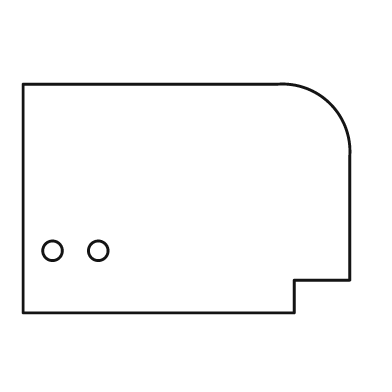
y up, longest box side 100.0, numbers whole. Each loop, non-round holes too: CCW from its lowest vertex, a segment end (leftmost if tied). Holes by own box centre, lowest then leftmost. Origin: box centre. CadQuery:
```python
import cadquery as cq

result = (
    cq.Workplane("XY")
    .moveTo(-50.0, -35.0)
    .lineTo(33.0, -35.0)
    .lineTo(33.0, -25.0)
    .lineTo(50.0, -25.0)
    .lineTo(50.0, 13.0)
    .threePointArc((44.0, 29.0), (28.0, 35.0))
    .lineTo(-50.0, 35.0)
    .close()
    .moveTo(-41.0, -16.0)
    .circle(3.0)
    .moveTo(-27.0, -16.0)
    .circle(3.0)
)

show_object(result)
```